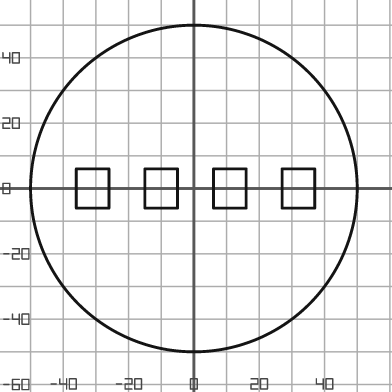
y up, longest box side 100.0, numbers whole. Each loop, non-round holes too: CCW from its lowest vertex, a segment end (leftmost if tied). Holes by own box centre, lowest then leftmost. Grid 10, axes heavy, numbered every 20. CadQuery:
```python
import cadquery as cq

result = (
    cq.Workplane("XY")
    .moveTo(0.0, 0.0)
    .circle(50.0)
    .moveTo(-36.0, -6.0)
    .lineTo(-26.0, -6.0)
    .lineTo(-26.0, 6.0)
    .lineTo(-36.0, 6.0)
    .close()
    .moveTo(-15.0, -6.0)
    .lineTo(-5.0, -6.0)
    .lineTo(-5.0, 6.0)
    .lineTo(-15.0, 6.0)
    .close()
    .moveTo(6.0, -6.0)
    .lineTo(16.0, -6.0)
    .lineTo(16.0, 6.0)
    .lineTo(6.0, 6.0)
    .close()
    .moveTo(27.0, -6.0)
    .lineTo(37.0, -6.0)
    .lineTo(37.0, 6.0)
    .lineTo(27.0, 6.0)
    .close()
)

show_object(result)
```